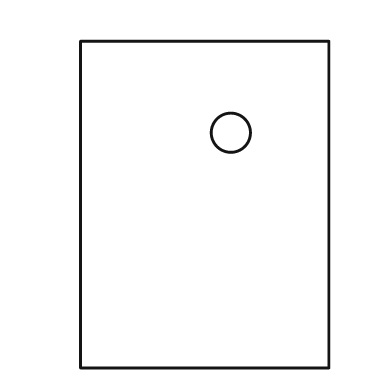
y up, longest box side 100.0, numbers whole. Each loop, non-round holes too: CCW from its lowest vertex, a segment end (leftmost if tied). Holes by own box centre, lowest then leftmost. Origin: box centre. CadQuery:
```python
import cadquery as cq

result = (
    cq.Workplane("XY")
    .moveTo(-38.0, -50.0)
    .lineTo(38.0, -50.0)
    .lineTo(38.0, 50.0)
    .lineTo(-38.0, 50.0)
    .close()
    .moveTo(8.0, 22.0)
    .circle(6.0)
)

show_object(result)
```